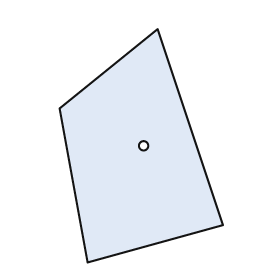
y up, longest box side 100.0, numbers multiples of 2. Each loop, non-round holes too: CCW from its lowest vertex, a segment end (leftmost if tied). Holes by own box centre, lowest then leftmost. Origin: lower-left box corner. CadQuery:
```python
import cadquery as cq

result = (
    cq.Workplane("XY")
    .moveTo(12.0, 0.0)
    .lineTo(70.0, 16.0)
    .lineTo(42.0, 100.0)
    .lineTo(0.0, 66.0)
    .close()
    .moveTo(36.0, 50.0)
    .circle(2.0)
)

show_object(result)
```